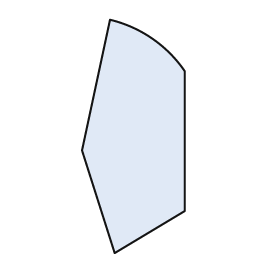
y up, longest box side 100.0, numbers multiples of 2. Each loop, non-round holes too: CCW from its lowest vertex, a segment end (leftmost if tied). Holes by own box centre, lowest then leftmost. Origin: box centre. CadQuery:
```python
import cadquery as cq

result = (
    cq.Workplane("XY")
    .moveTo(-8.0, -50.0)
    .lineTo(22.0, -32.0)
    .lineTo(22.0, 28.0)
    .threePointArc((8.0, 42.0), (-10.0, 50.0))
    .lineTo(-22.0, -6.0)
    .close()
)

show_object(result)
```